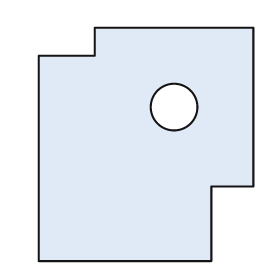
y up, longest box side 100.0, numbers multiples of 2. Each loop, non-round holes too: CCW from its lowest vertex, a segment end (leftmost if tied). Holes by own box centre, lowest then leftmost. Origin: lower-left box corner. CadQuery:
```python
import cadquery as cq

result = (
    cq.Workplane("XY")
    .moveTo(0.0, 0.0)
    .lineTo(74.0, 0.0)
    .lineTo(74.0, 32.0)
    .lineTo(92.0, 32.0)
    .lineTo(92.0, 100.0)
    .lineTo(24.0, 100.0)
    .lineTo(24.0, 88.0)
    .lineTo(0.0, 88.0)
    .close()
    .moveTo(58.0, 66.0)
    .circle(10.0)
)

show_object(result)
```